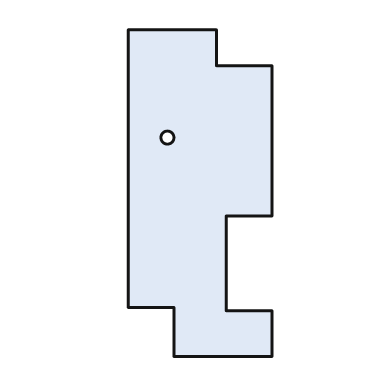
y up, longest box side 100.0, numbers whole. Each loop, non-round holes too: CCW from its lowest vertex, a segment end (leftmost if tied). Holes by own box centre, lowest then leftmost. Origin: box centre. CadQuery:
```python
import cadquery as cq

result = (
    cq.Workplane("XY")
    .moveTo(-8.0, -50.0)
    .lineTo(22.0, -50.0)
    .lineTo(22.0, -36.0)
    .lineTo(8.0, -36.0)
    .lineTo(8.0, -7.0)
    .lineTo(22.0, -7.0)
    .lineTo(22.0, 39.0)
    .lineTo(5.0, 39.0)
    .lineTo(5.0, 50.0)
    .lineTo(-22.0, 50.0)
    .lineTo(-22.0, -35.0)
    .lineTo(-8.0, -35.0)
    .close()
    .moveTo(-10.0, 17.0)
    .circle(2.0)
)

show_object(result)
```